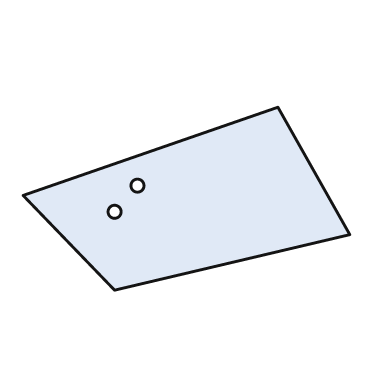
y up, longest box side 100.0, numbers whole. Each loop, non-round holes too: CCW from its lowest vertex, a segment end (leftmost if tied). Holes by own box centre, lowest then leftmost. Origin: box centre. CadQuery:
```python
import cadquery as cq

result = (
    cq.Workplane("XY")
    .moveTo(-22.0, -28.0)
    .lineTo(50.0, -11.0)
    .lineTo(28.0, 28.0)
    .lineTo(-50.0, 1.0)
    .close()
    .moveTo(-22.0, -4.0)
    .circle(2.0)
    .moveTo(-15.0, 4.0)
    .circle(2.0)
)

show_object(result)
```